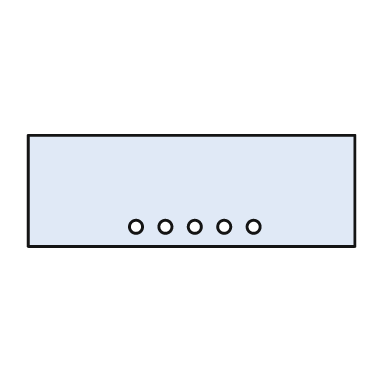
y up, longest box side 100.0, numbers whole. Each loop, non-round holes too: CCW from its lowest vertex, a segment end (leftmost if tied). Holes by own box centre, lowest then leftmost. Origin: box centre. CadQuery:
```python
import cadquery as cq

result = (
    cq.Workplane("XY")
    .moveTo(-50.0, -17.0)
    .lineTo(50.0, -17.0)
    .lineTo(50.0, 17.0)
    .lineTo(-50.0, 17.0)
    .close()
    .moveTo(-17.0, -11.0)
    .circle(2.0)
    .moveTo(-8.0, -11.0)
    .circle(2.0)
    .moveTo(1.0, -11.0)
    .circle(2.0)
    .moveTo(10.0, -11.0)
    .circle(2.0)
    .moveTo(19.0, -11.0)
    .circle(2.0)
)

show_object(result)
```